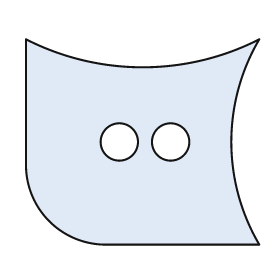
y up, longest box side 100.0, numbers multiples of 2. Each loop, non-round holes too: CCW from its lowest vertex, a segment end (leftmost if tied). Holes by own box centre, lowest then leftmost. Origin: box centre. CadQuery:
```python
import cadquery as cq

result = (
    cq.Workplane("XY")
    .moveTo(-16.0, -44.0)
    .lineTo(50.0, -44.0)
    .threePointArc((38.0, 0.0), (50.0, 44.0))
    .threePointArc((0.0, 32.0), (-50.0, 44.0))
    .lineTo(-50.0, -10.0)
    .threePointArc((-40.0, -34.0), (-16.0, -44.0))
    .close()
    .moveTo(-10.0, 0.0)
    .circle(8.0)
    .moveTo(12.0, 0.0)
    .circle(8.0)
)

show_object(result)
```